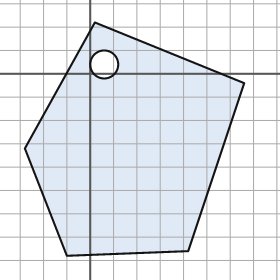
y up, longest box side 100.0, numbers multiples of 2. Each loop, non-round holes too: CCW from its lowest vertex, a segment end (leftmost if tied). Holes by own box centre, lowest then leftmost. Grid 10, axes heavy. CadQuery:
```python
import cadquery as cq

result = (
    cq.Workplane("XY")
    .moveTo(-10.0, -78.0)
    .lineTo(42.0, -76.0)
    .lineTo(66.0, -4.0)
    .lineTo(2.0, 22.0)
    .lineTo(-28.0, -32.0)
    .close()
    .moveTo(6.0, 4.0)
    .circle(6.0)
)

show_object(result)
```